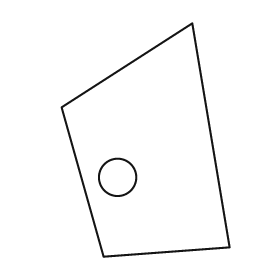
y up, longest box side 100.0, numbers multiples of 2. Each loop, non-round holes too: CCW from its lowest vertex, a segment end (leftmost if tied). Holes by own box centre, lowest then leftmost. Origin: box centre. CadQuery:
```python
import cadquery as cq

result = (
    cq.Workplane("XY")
    .moveTo(-18.0, -50.0)
    .lineTo(36.0, -46.0)
    .lineTo(20.0, 50.0)
    .lineTo(-36.0, 14.0)
    .close()
    .moveTo(-12.0, -16.0)
    .circle(8.0)
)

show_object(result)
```